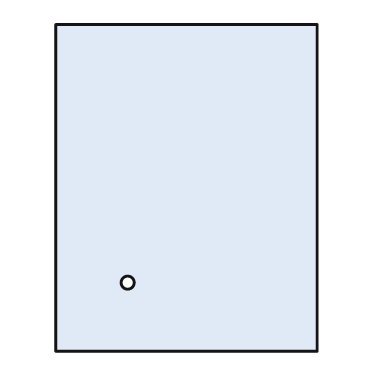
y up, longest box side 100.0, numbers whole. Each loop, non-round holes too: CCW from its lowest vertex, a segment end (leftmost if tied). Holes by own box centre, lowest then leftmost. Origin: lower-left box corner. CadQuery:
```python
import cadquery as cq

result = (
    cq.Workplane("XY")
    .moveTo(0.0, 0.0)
    .lineTo(80.0, 0.0)
    .lineTo(80.0, 100.0)
    .lineTo(0.0, 100.0)
    .close()
    .moveTo(22.0, 21.0)
    .circle(2.0)
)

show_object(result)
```